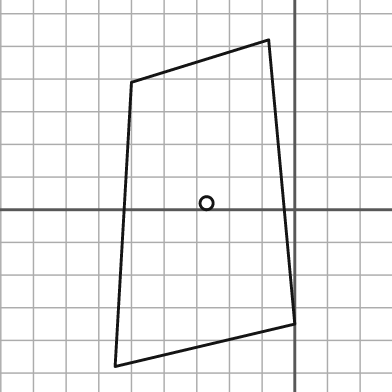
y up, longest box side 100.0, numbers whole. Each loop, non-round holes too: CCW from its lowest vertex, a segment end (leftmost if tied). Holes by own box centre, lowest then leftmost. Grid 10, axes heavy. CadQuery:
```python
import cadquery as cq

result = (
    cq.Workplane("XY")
    .moveTo(-55.0, -48.0)
    .lineTo(0.0, -35.0)
    .lineTo(-8.0, 52.0)
    .lineTo(-50.0, 39.0)
    .close()
    .moveTo(-27.0, 2.0)
    .circle(2.0)
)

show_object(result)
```